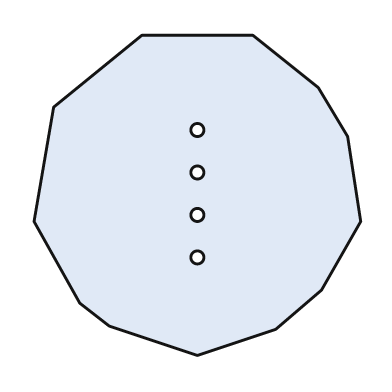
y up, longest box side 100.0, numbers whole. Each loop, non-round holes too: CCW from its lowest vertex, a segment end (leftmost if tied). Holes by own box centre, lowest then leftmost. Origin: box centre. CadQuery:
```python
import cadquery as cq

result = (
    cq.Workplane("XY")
    .moveTo(0.0, -49.0)
    .lineTo(24.0, -41.0)
    .lineTo(38.0, -29.0)
    .lineTo(50.0, -8.0)
    .lineTo(46.0, 18.0)
    .lineTo(37.0, 33.0)
    .lineTo(17.0, 49.0)
    .lineTo(-17.0, 49.0)
    .lineTo(-44.0, 27.0)
    .lineTo(-50.0, -8.0)
    .lineTo(-36.0, -33.0)
    .lineTo(-27.0, -40.0)
    .close()
    .moveTo(0.0, -19.0)
    .circle(2.0)
    .moveTo(0.0, -6.0)
    .circle(2.0)
    .moveTo(0.0, 7.0)
    .circle(2.0)
    .moveTo(0.0, 20.0)
    .circle(2.0)
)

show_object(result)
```